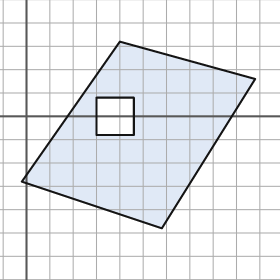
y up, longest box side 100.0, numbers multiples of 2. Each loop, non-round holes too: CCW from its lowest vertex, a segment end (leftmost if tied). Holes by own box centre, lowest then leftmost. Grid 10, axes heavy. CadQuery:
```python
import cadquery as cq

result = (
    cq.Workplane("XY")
    .moveTo(58.0, -48.0)
    .lineTo(98.0, 16.0)
    .lineTo(40.0, 32.0)
    .lineTo(-2.0, -28.0)
    .close()
    .moveTo(30.0, -8.0)
    .lineTo(46.0, -8.0)
    .lineTo(46.0, 8.0)
    .lineTo(30.0, 8.0)
    .close()
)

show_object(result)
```